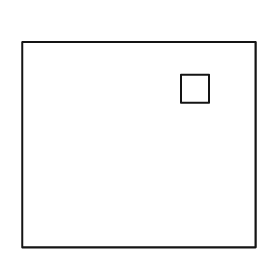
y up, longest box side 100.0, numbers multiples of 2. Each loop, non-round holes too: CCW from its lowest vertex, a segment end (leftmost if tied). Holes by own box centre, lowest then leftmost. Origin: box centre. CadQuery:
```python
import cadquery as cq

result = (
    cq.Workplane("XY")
    .moveTo(-50.0, -44.0)
    .lineTo(50.0, -44.0)
    .lineTo(50.0, 44.0)
    .lineTo(-50.0, 44.0)
    .close()
    .moveTo(18.0, 18.0)
    .lineTo(30.0, 18.0)
    .lineTo(30.0, 30.0)
    .lineTo(18.0, 30.0)
    .close()
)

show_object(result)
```